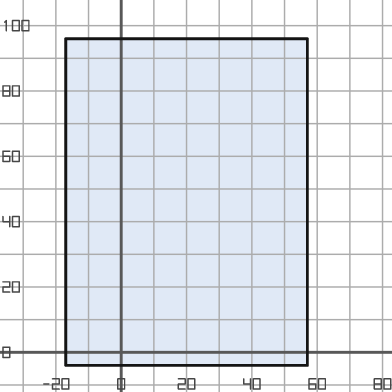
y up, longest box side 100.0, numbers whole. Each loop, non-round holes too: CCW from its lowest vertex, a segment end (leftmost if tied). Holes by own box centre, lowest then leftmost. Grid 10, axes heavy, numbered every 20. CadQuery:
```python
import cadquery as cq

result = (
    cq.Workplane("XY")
    .moveTo(-17.0, -4.0)
    .lineTo(57.0, -4.0)
    .lineTo(57.0, 96.0)
    .lineTo(-17.0, 96.0)
    .close()
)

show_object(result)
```